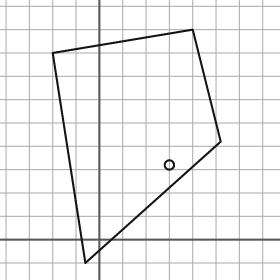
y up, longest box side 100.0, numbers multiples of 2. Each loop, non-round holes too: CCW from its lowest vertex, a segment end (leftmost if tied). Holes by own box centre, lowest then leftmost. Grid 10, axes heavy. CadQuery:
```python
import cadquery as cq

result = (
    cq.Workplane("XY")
    .moveTo(-6.0, -10.0)
    .lineTo(52.0, 42.0)
    .lineTo(40.0, 90.0)
    .lineTo(-20.0, 80.0)
    .close()
    .moveTo(30.0, 32.0)
    .circle(2.0)
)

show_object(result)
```